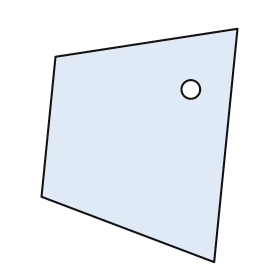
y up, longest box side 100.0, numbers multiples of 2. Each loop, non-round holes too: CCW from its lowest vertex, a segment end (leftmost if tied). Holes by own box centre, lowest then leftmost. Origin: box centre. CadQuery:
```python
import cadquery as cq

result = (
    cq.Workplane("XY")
    .moveTo(32.0, -50.0)
    .lineTo(42.0, 50.0)
    .lineTo(-36.0, 38.0)
    .lineTo(-42.0, -22.0)
    .close()
    .moveTo(22.0, 24.0)
    .circle(4.0)
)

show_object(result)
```